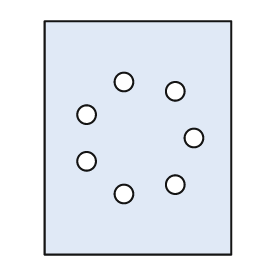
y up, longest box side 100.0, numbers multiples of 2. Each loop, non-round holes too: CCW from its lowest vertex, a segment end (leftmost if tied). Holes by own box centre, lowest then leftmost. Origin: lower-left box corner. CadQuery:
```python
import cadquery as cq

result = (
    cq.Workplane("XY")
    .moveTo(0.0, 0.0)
    .lineTo(80.0, 0.0)
    .lineTo(80.0, 100.0)
    .lineTo(0.0, 100.0)
    .close()
    .moveTo(34.0, 26.0)
    .circle(4.0)
    .moveTo(56.0, 30.0)
    .circle(4.0)
    .moveTo(18.0, 40.0)
    .circle(4.0)
    .moveTo(64.0, 50.0)
    .circle(4.0)
    .moveTo(18.0, 60.0)
    .circle(4.0)
    .moveTo(56.0, 70.0)
    .circle(4.0)
    .moveTo(34.0, 74.0)
    .circle(4.0)
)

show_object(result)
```